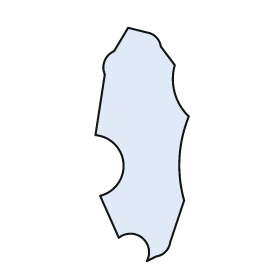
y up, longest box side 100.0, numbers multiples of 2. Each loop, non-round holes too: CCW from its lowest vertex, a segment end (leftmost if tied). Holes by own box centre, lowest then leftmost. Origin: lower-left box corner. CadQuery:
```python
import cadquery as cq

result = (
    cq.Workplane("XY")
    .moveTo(22.0, 0.0)
    .lineTo(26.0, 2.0)
    .threePointArc((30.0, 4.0), (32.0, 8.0))
    .lineTo(38.0, 26.0)
    .threePointArc((36.0, 44.0), (40.0, 62.0))
    .threePointArc((34.0, 72.0), (34.0, 84.0))
    .lineTo(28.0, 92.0)
    .threePointArc((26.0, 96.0), (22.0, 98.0))
    .lineTo(14.0, 100.0)
    .lineTo(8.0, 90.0)
    .threePointArc((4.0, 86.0), (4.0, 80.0))
    .lineTo(0.0, 54.0)
    .threePointArc((12.0, 42.0), (2.0, 28.0))
    .lineTo(10.0, 10.0)
    .threePointArc((20.0, 10.0), (22.0, 0.0))
    .close()
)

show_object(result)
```